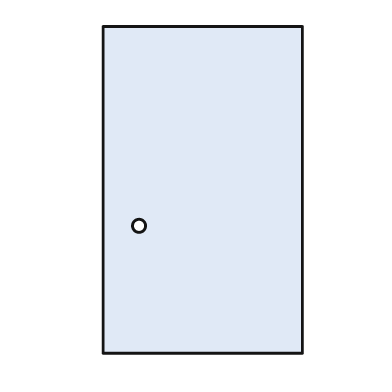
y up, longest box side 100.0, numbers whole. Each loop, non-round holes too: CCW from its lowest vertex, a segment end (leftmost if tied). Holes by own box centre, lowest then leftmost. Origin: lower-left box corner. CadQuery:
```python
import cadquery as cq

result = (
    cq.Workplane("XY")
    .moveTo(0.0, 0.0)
    .lineTo(61.0, 0.0)
    .lineTo(61.0, 100.0)
    .lineTo(0.0, 100.0)
    .close()
    .moveTo(11.0, 39.0)
    .circle(2.0)
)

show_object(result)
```